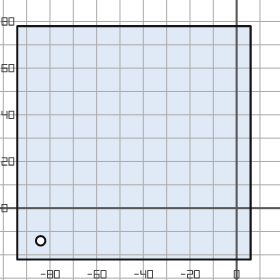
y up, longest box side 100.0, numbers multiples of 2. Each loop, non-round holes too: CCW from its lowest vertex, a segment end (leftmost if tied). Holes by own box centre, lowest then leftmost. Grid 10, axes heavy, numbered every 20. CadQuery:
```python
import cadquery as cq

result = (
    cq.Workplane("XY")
    .moveTo(-94.0, -22.0)
    .lineTo(6.0, -22.0)
    .lineTo(6.0, 78.0)
    .lineTo(-94.0, 78.0)
    .close()
    .moveTo(-84.0, -14.0)
    .circle(2.0)
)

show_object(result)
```